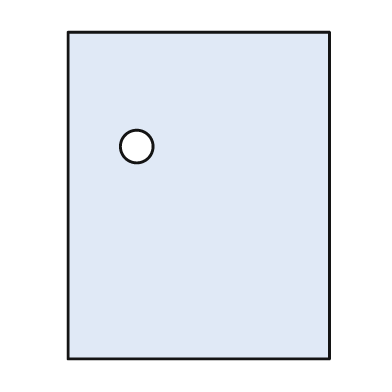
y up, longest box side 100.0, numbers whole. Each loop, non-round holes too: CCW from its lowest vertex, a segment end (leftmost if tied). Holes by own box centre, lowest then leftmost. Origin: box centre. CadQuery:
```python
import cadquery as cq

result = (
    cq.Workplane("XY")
    .moveTo(-40.0, -50.0)
    .lineTo(40.0, -50.0)
    .lineTo(40.0, 50.0)
    .lineTo(-40.0, 50.0)
    .close()
    .moveTo(-19.0, 15.0)
    .circle(5.0)
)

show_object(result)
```